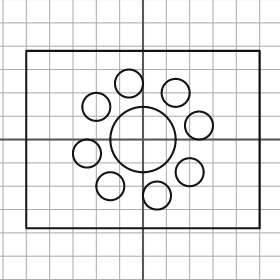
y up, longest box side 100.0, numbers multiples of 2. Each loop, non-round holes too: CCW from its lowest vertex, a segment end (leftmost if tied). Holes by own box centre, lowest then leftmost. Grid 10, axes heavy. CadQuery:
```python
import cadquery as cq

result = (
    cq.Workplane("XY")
    .moveTo(-50.0, -38.0)
    .lineTo(50.0, -38.0)
    .lineTo(50.0, 38.0)
    .lineTo(-50.0, 38.0)
    .close()
    .moveTo(6.0, -24.0)
    .circle(6.0)
    .moveTo(-14.0, -20.0)
    .circle(6.0)
    .moveTo(20.0, -14.0)
    .circle(6.0)
    .moveTo(-24.0, -6.0)
    .circle(6.0)
    .moveTo(0.0, 0.0)
    .circle(14.0)
    .moveTo(24.0, 6.0)
    .circle(6.0)
    .moveTo(-20.0, 14.0)
    .circle(6.0)
    .moveTo(14.0, 20.0)
    .circle(6.0)
    .moveTo(-6.0, 24.0)
    .circle(6.0)
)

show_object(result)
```